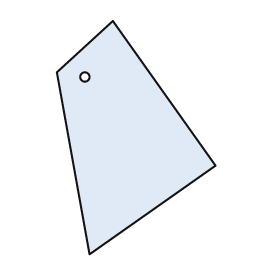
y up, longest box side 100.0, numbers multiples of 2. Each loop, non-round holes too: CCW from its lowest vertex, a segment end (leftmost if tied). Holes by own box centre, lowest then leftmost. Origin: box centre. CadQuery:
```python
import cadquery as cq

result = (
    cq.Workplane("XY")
    .moveTo(-20.0, -50.0)
    .lineTo(34.0, -12.0)
    .lineTo(-10.0, 50.0)
    .lineTo(-34.0, 28.0)
    .close()
    .moveTo(-22.0, 26.0)
    .circle(2.0)
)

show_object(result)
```